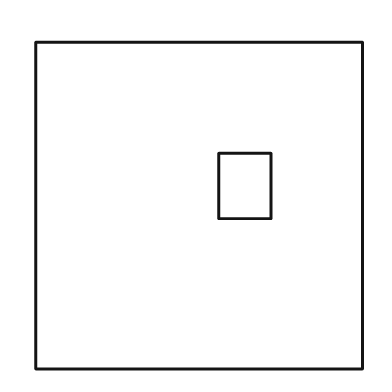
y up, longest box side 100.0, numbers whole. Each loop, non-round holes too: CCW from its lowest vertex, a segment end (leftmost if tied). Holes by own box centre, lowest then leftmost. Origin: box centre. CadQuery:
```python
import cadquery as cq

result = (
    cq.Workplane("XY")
    .moveTo(-50.0, -50.0)
    .lineTo(50.0, -50.0)
    .lineTo(50.0, 50.0)
    .lineTo(-50.0, 50.0)
    .close()
    .moveTo(6.0, -4.0)
    .lineTo(22.0, -4.0)
    .lineTo(22.0, 16.0)
    .lineTo(6.0, 16.0)
    .close()
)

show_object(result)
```